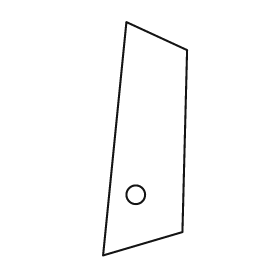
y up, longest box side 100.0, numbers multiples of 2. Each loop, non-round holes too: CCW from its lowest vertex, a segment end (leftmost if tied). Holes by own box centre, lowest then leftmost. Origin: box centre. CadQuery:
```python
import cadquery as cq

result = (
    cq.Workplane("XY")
    .moveTo(-18.0, -50.0)
    .lineTo(16.0, -40.0)
    .lineTo(18.0, 38.0)
    .lineTo(-8.0, 50.0)
    .close()
    .moveTo(-4.0, -24.0)
    .circle(4.0)
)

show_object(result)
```